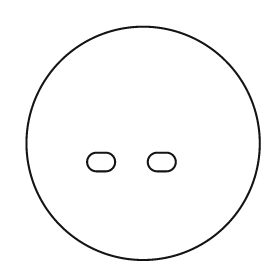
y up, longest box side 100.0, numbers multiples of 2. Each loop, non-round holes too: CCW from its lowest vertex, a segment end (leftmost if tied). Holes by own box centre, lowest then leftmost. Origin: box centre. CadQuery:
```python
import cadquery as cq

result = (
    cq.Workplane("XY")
    .moveTo(0.0, 0.0)
    .circle(50.0)
    .moveTo(-20.0, -12.0)
    .lineTo(-16.0, -12.0)
    .threePointArc((-12.0, -8.0), (-16.0, -4.0))
    .lineTo(-20.0, -4.0)
    .threePointArc((-24.0, -8.0), (-20.0, -12.0))
    .close()
    .moveTo(6.0, -12.0)
    .lineTo(10.0, -12.0)
    .threePointArc((14.0, -8.0), (10.0, -4.0))
    .lineTo(6.0, -4.0)
    .threePointArc((2.0, -8.0), (6.0, -12.0))
    .close()
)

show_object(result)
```